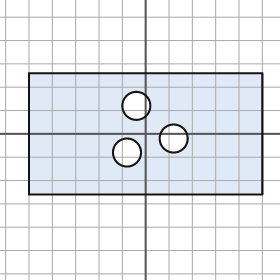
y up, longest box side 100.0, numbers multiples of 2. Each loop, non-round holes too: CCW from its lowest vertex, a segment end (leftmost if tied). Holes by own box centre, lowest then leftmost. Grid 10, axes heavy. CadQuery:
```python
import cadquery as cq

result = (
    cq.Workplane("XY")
    .moveTo(-50.0, -26.0)
    .lineTo(50.0, -26.0)
    .lineTo(50.0, 26.0)
    .lineTo(-50.0, 26.0)
    .close()
    .moveTo(-8.0, -8.0)
    .circle(6.0)
    .moveTo(12.0, -2.0)
    .circle(6.0)
    .moveTo(-4.0, 12.0)
    .circle(6.0)
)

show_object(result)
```